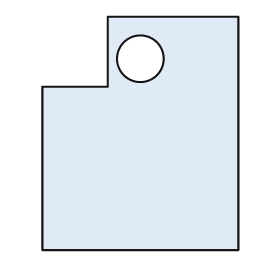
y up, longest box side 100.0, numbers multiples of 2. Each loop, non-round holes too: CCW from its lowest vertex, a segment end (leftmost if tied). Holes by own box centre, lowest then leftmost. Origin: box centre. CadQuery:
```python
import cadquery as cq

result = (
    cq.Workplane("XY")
    .moveTo(-42.0, -50.0)
    .lineTo(42.0, -50.0)
    .lineTo(42.0, 50.0)
    .lineTo(-14.0, 50.0)
    .lineTo(-14.0, 20.0)
    .lineTo(-42.0, 20.0)
    .close()
    .moveTo(0.0, 32.0)
    .circle(10.0)
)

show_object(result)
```